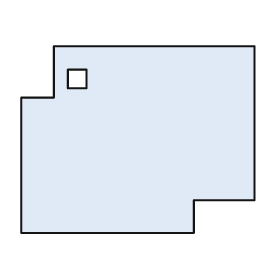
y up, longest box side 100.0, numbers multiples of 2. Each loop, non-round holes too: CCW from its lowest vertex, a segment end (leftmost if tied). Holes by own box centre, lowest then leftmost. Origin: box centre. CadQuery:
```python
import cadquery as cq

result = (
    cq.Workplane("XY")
    .moveTo(-50.0, -40.0)
    .lineTo(24.0, -40.0)
    .lineTo(24.0, -26.0)
    .lineTo(50.0, -26.0)
    .lineTo(50.0, 40.0)
    .lineTo(-36.0, 40.0)
    .lineTo(-36.0, 18.0)
    .lineTo(-50.0, 18.0)
    .close()
    .moveTo(-30.0, 22.0)
    .lineTo(-22.0, 22.0)
    .lineTo(-22.0, 30.0)
    .lineTo(-30.0, 30.0)
    .close()
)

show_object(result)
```